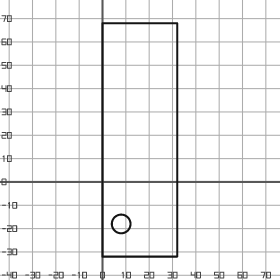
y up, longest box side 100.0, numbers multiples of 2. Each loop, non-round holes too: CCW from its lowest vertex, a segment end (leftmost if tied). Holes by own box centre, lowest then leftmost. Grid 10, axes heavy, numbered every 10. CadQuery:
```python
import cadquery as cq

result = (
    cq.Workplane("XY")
    .moveTo(0.0, -32.0)
    .lineTo(32.0, -32.0)
    .lineTo(32.0, 68.0)
    .lineTo(0.0, 68.0)
    .close()
    .moveTo(8.0, -18.0)
    .circle(4.0)
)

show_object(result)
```